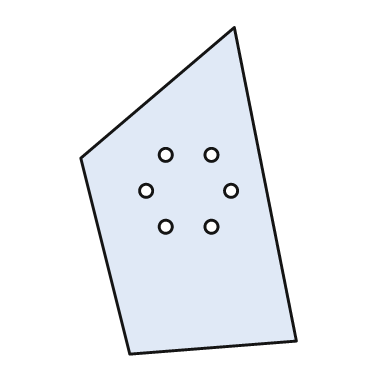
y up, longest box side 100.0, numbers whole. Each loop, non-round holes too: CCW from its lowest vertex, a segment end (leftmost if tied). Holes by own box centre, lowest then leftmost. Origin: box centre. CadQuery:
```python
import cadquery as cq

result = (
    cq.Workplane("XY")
    .moveTo(-18.0, -50.0)
    .lineTo(33.0, -46.0)
    .lineTo(14.0, 50.0)
    .lineTo(-33.0, 10.0)
    .close()
    .moveTo(-7.0, -11.0)
    .circle(2.0)
    .moveTo(7.0, -11.0)
    .circle(2.0)
    .moveTo(-13.0, 0.0)
    .circle(2.0)
    .moveTo(13.0, 0.0)
    .circle(2.0)
    .moveTo(-7.0, 11.0)
    .circle(2.0)
    .moveTo(7.0, 11.0)
    .circle(2.0)
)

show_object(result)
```